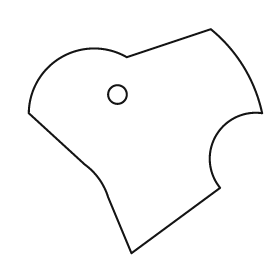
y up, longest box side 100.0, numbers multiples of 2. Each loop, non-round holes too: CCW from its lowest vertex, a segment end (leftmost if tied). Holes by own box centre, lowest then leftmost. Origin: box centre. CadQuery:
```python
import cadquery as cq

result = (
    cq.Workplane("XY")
    .moveTo(-6.0, -48.0)
    .lineTo(32.0, -20.0)
    .threePointArc((30.0, 2.0), (50.0, 12.0))
    .threePointArc((42.0, 32.0), (28.0, 48.0))
    .lineTo(-8.0, 36.0)
    .threePointArc((-36.0, 36.0), (-50.0, 12.0))
    .lineTo(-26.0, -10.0)
    .threePointArc((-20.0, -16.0), (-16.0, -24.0))
    .close()
    .moveTo(-12.0, 20.0)
    .circle(4.0)
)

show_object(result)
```